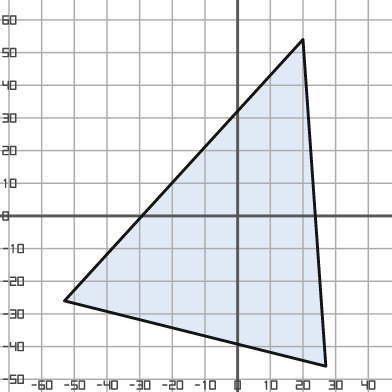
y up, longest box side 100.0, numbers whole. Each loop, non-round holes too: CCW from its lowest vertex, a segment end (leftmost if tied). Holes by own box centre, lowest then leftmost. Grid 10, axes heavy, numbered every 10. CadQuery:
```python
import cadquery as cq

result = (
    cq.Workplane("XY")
    .moveTo(27.0, -46.0)
    .lineTo(20.0, 54.0)
    .lineTo(-53.0, -26.0)
    .close()
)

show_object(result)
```